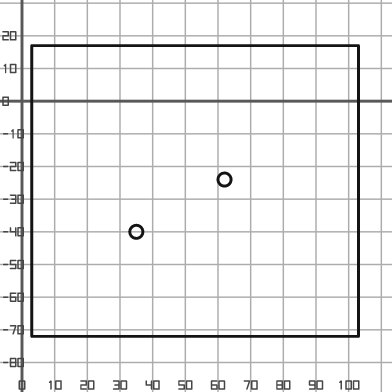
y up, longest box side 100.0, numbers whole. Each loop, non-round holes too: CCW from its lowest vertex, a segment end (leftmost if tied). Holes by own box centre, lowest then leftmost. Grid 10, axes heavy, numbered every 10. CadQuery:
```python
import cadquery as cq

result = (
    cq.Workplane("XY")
    .moveTo(3.0, -72.0)
    .lineTo(103.0, -72.0)
    .lineTo(103.0, 17.0)
    .lineTo(3.0, 17.0)
    .close()
    .moveTo(35.0, -40.0)
    .circle(2.0)
    .moveTo(62.0, -24.0)
    .circle(2.0)
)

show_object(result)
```